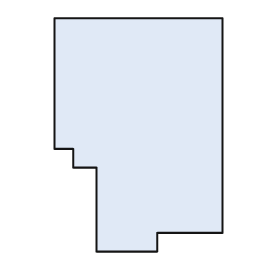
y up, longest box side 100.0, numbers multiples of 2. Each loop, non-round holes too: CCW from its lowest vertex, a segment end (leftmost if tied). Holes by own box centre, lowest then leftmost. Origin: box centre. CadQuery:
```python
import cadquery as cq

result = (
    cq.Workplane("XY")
    .moveTo(-18.0, -50.0)
    .lineTo(8.0, -50.0)
    .lineTo(8.0, -42.0)
    .lineTo(36.0, -42.0)
    .lineTo(36.0, 50.0)
    .lineTo(-36.0, 50.0)
    .lineTo(-36.0, -6.0)
    .lineTo(-28.0, -6.0)
    .lineTo(-28.0, -14.0)
    .lineTo(-18.0, -14.0)
    .close()
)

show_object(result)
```